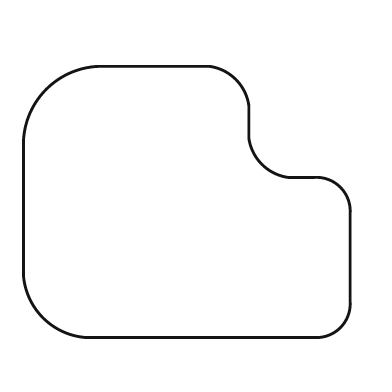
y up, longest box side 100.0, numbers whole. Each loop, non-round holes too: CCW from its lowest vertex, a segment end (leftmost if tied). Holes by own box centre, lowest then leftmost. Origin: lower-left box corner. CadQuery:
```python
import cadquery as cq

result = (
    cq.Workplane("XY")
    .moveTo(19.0, 0.0)
    .lineTo(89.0, 0.0)
    .threePointArc((97.0, 3.0), (100.0, 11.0))
    .lineTo(100.0, 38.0)
    .threePointArc((97.0, 46.0), (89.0, 49.0))
    .lineTo(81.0, 49.0)
    .threePointArc((73.0, 53.0), (69.0, 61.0))
    .lineTo(69.0, 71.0)
    .threePointArc((65.0, 79.0), (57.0, 83.0))
    .lineTo(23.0, 83.0)
    .threePointArc((7.0, 76.0), (0.0, 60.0))
    .lineTo(0.0, 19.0)
    .threePointArc((6.0, 6.0), (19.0, 0.0))
    .close()
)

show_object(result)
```